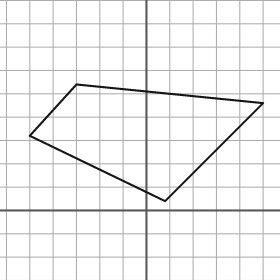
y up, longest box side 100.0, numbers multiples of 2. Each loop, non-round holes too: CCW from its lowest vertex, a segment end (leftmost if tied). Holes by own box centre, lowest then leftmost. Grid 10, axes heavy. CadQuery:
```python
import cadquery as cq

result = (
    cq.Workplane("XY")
    .moveTo(8.0, 4.0)
    .lineTo(50.0, 46.0)
    .lineTo(-30.0, 54.0)
    .lineTo(-50.0, 32.0)
    .close()
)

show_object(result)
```